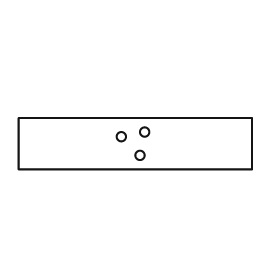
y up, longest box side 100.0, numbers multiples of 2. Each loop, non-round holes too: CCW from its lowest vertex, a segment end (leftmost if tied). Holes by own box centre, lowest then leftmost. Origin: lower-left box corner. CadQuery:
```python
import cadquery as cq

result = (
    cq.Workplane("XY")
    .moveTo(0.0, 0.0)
    .lineTo(100.0, 0.0)
    .lineTo(100.0, 22.0)
    .lineTo(0.0, 22.0)
    .close()
    .moveTo(52.0, 6.0)
    .circle(2.0)
    .moveTo(44.0, 14.0)
    .circle(2.0)
    .moveTo(54.0, 16.0)
    .circle(2.0)
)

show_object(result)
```